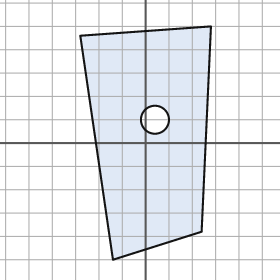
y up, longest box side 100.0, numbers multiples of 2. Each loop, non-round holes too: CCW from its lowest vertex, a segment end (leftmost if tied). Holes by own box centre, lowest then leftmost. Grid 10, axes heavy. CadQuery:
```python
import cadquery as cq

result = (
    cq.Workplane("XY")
    .moveTo(-14.0, -50.0)
    .lineTo(24.0, -38.0)
    .lineTo(28.0, 50.0)
    .lineTo(-28.0, 46.0)
    .close()
    .moveTo(4.0, 10.0)
    .circle(6.0)
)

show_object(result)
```